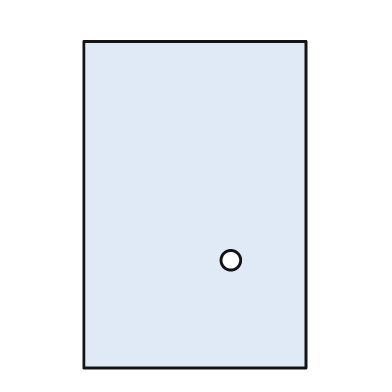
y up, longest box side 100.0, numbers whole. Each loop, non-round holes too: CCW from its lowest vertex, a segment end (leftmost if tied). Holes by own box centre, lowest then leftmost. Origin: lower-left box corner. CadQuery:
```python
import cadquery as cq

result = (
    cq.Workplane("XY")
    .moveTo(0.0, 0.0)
    .lineTo(68.0, 0.0)
    .lineTo(68.0, 100.0)
    .lineTo(0.0, 100.0)
    .close()
    .moveTo(45.0, 33.0)
    .circle(3.0)
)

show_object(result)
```